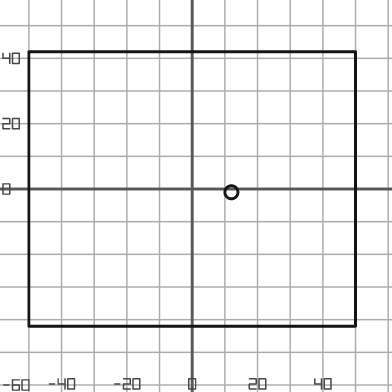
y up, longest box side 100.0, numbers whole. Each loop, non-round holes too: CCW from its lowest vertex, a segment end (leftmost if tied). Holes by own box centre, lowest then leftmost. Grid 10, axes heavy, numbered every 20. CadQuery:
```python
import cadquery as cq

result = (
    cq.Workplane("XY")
    .moveTo(-50.0, -42.0)
    .lineTo(50.0, -42.0)
    .lineTo(50.0, 42.0)
    .lineTo(-50.0, 42.0)
    .close()
    .moveTo(12.0, -1.0)
    .circle(2.0)
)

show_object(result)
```